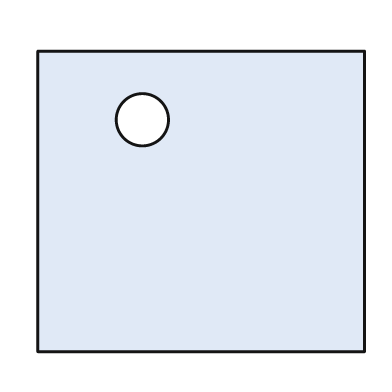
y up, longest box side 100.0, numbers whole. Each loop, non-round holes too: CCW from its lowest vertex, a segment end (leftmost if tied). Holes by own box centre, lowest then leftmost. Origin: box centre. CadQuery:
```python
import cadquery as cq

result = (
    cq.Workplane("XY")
    .moveTo(-50.0, -46.0)
    .lineTo(50.0, -46.0)
    .lineTo(50.0, 46.0)
    .lineTo(-50.0, 46.0)
    .close()
    .moveTo(-18.0, 25.0)
    .circle(8.0)
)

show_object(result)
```